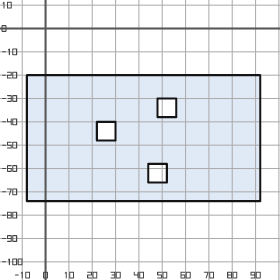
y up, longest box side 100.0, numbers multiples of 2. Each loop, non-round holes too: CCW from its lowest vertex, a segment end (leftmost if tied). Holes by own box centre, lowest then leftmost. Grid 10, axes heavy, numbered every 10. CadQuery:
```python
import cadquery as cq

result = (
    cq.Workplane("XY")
    .moveTo(-8.0, -74.0)
    .lineTo(92.0, -74.0)
    .lineTo(92.0, -20.0)
    .lineTo(-8.0, -20.0)
    .close()
    .moveTo(44.0, -66.0)
    .lineTo(52.0, -66.0)
    .lineTo(52.0, -58.0)
    .lineTo(44.0, -58.0)
    .close()
    .moveTo(22.0, -48.0)
    .lineTo(30.0, -48.0)
    .lineTo(30.0, -40.0)
    .lineTo(22.0, -40.0)
    .close()
    .moveTo(48.0, -38.0)
    .lineTo(56.0, -38.0)
    .lineTo(56.0, -30.0)
    .lineTo(48.0, -30.0)
    .close()
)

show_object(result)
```